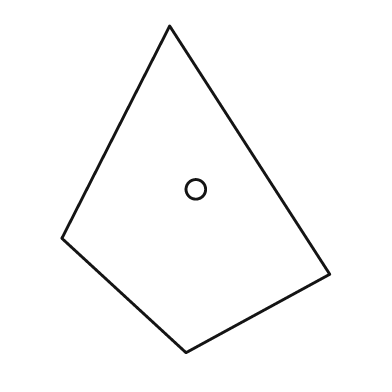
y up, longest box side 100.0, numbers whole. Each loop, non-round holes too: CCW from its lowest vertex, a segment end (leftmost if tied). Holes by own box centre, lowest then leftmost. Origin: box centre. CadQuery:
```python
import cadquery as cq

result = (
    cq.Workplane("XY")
    .moveTo(-3.0, -50.0)
    .lineTo(41.0, -26.0)
    .lineTo(-8.0, 50.0)
    .lineTo(-41.0, -15.0)
    .close()
    .moveTo(0.0, 0.0)
    .circle(3.0)
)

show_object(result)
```